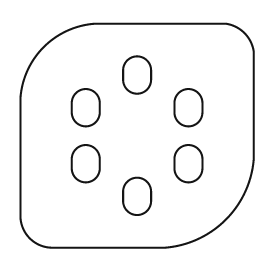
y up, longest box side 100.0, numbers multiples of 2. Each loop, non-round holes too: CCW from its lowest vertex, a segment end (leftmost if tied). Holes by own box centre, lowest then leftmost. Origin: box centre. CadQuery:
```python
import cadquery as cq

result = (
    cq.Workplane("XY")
    .moveTo(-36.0, -48.0)
    .lineTo(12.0, -48.0)
    .threePointArc((38.0, -36.0), (50.0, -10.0))
    .lineTo(50.0, 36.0)
    .threePointArc((46.0, 44.0), (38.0, 48.0))
    .lineTo(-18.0, 48.0)
    .threePointArc((-40.0, 38.0), (-50.0, 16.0))
    .lineTo(-50.0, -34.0)
    .threePointArc((-46.0, -44.0), (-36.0, -48.0))
    .close()
    .moveTo(-6.0, -28.0)
    .threePointArc((0.0, -34.0), (6.0, -28.0))
    .lineTo(6.0, -24.0)
    .threePointArc((0.0, -18.0), (-6.0, -24.0))
    .close()
    .moveTo(-28.0, -14.0)
    .threePointArc((-22.0, -20.0), (-16.0, -14.0))
    .lineTo(-16.0, -10.0)
    .threePointArc((-22.0, -4.0), (-28.0, -10.0))
    .close()
    .moveTo(16.0, -14.0)
    .threePointArc((22.0, -20.0), (28.0, -14.0))
    .lineTo(28.0, -10.0)
    .threePointArc((22.0, -4.0), (16.0, -10.0))
    .close()
    .moveTo(-28.0, 10.0)
    .threePointArc((-22.0, 4.0), (-16.0, 10.0))
    .lineTo(-16.0, 14.0)
    .threePointArc((-22.0, 20.0), (-28.0, 14.0))
    .close()
    .moveTo(16.0, 10.0)
    .threePointArc((22.0, 4.0), (28.0, 10.0))
    .lineTo(28.0, 14.0)
    .threePointArc((22.0, 20.0), (16.0, 14.0))
    .close()
    .moveTo(-6.0, 24.0)
    .threePointArc((0.0, 18.0), (6.0, 24.0))
    .lineTo(6.0, 28.0)
    .threePointArc((0.0, 34.0), (-6.0, 28.0))
    .close()
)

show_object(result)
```